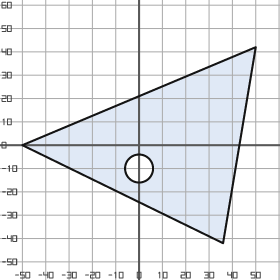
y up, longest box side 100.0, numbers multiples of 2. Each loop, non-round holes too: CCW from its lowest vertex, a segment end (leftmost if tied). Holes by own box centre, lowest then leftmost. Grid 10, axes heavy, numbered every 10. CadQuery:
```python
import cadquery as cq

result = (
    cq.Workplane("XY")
    .moveTo(36.0, -42.0)
    .lineTo(50.0, 42.0)
    .lineTo(-50.0, 0.0)
    .close()
    .moveTo(0.0, -10.0)
    .circle(6.0)
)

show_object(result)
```